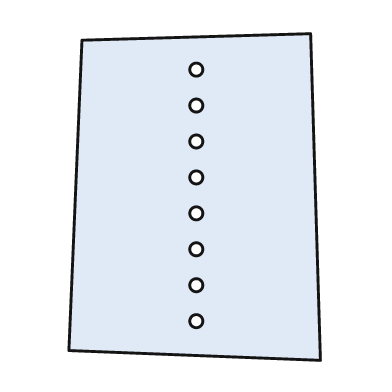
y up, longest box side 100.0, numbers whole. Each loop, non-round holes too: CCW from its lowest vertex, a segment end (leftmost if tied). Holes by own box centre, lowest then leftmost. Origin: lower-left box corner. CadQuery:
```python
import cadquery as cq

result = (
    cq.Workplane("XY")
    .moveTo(77.0, 0.0)
    .lineTo(74.0, 100.0)
    .lineTo(4.0, 98.0)
    .lineTo(0.0, 3.0)
    .close()
    .moveTo(39.0, 12.0)
    .circle(2.0)
    .moveTo(39.0, 23.0)
    .circle(2.0)
    .moveTo(39.0, 34.0)
    .circle(2.0)
    .moveTo(39.0, 45.0)
    .circle(2.0)
    .moveTo(39.0, 56.0)
    .circle(2.0)
    .moveTo(39.0, 67.0)
    .circle(2.0)
    .moveTo(39.0, 78.0)
    .circle(2.0)
    .moveTo(39.0, 89.0)
    .circle(2.0)
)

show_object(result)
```